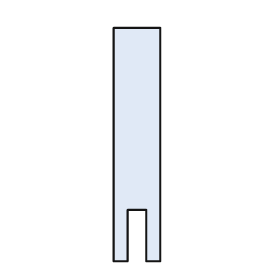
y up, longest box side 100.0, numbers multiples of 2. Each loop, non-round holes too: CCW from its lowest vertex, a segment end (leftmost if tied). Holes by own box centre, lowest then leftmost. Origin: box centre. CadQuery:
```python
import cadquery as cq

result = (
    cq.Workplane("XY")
    .moveTo(-10.0, -50.0)
    .lineTo(-4.0, -50.0)
    .lineTo(-4.0, -28.0)
    .lineTo(4.0, -28.0)
    .lineTo(4.0, -50.0)
    .lineTo(10.0, -50.0)
    .lineTo(10.0, 50.0)
    .lineTo(-10.0, 50.0)
    .close()
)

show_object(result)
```